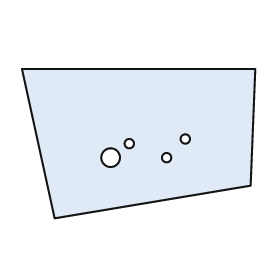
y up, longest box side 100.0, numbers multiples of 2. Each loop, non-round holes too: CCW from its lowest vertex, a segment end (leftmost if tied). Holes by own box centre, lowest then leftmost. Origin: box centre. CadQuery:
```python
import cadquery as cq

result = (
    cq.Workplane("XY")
    .moveTo(-36.0, -32.0)
    .lineTo(48.0, -18.0)
    .lineTo(50.0, 32.0)
    .lineTo(-50.0, 32.0)
    .close()
    .moveTo(-12.0, -6.0)
    .circle(4.0)
    .moveTo(12.0, -6.0)
    .circle(2.0)
    .moveTo(-4.0, 0.0)
    .circle(2.0)
    .moveTo(20.0, 2.0)
    .circle(2.0)
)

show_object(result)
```